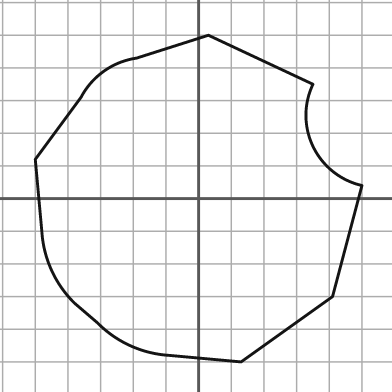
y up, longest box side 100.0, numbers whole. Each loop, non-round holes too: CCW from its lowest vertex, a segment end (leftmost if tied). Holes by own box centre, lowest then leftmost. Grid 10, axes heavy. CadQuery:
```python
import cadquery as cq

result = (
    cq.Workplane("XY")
    .moveTo(13.0, -50.0)
    .lineTo(41.0, -30.0)
    .lineTo(50.0, 4.0)
    .threePointArc((35.0, 16.0), (35.0, 35.0))
    .lineTo(3.0, 50.0)
    .lineTo(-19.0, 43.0)
    .threePointArc((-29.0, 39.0), (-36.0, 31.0))
    .lineTo(-50.0, 12.0)
    .lineTo(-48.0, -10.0)
    .threePointArc((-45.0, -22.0), (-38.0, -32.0))
    .lineTo(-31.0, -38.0)
    .threePointArc((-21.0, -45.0), (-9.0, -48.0))
    .close()
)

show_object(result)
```